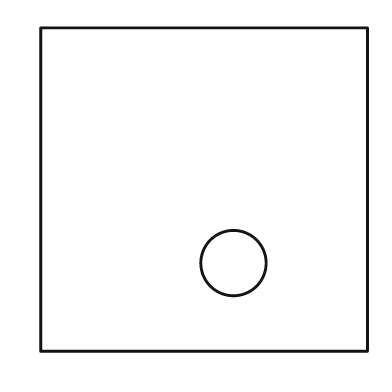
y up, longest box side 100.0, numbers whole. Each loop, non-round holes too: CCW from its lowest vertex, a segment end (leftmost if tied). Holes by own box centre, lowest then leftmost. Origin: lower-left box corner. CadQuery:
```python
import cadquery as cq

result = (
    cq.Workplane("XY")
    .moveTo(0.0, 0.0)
    .lineTo(100.0, 0.0)
    .lineTo(100.0, 99.0)
    .lineTo(0.0, 99.0)
    .close()
    .moveTo(59.0, 27.0)
    .circle(10.0)
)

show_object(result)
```